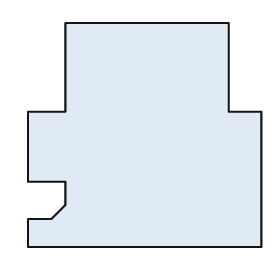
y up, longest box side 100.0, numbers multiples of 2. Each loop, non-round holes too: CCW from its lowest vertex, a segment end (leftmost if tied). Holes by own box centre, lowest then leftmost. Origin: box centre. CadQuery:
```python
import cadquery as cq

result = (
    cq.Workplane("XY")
    .moveTo(-50.0, -48.0)
    .lineTo(50.0, -48.0)
    .lineTo(50.0, 10.0)
    .lineTo(36.0, 10.0)
    .lineTo(36.0, 48.0)
    .lineTo(-34.0, 48.0)
    .lineTo(-34.0, 10.0)
    .lineTo(-50.0, 10.0)
    .lineTo(-50.0, -20.0)
    .lineTo(-34.0, -20.0)
    .lineTo(-34.0, -30.0)
    .lineTo(-40.0, -36.0)
    .lineTo(-50.0, -36.0)
    .close()
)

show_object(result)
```